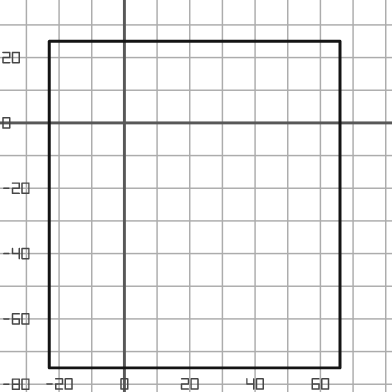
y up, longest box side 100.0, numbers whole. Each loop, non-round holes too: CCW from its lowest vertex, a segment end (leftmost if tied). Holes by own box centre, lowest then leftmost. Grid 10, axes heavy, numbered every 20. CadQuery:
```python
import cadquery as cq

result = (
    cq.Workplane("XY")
    .moveTo(-23.0, -75.0)
    .lineTo(66.0, -75.0)
    .lineTo(66.0, 25.0)
    .lineTo(-23.0, 25.0)
    .close()
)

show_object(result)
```